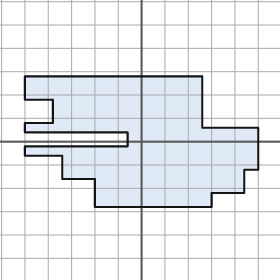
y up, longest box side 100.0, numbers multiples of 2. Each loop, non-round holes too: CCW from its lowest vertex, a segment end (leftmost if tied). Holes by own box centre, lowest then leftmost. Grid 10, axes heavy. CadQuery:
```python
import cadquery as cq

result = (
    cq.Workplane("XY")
    .moveTo(-20.0, -28.0)
    .lineTo(30.0, -28.0)
    .lineTo(30.0, -22.0)
    .lineTo(44.0, -22.0)
    .lineTo(44.0, -12.0)
    .lineTo(50.0, -12.0)
    .lineTo(50.0, 6.0)
    .lineTo(26.0, 6.0)
    .lineTo(26.0, 28.0)
    .lineTo(-50.0, 28.0)
    .lineTo(-50.0, 18.0)
    .lineTo(-38.0, 18.0)
    .lineTo(-38.0, 8.0)
    .lineTo(-50.0, 8.0)
    .lineTo(-50.0, 4.0)
    .lineTo(-6.0, 4.0)
    .lineTo(-6.0, -2.0)
    .lineTo(-50.0, -2.0)
    .lineTo(-50.0, -6.0)
    .lineTo(-34.0, -6.0)
    .lineTo(-34.0, -16.0)
    .lineTo(-20.0, -16.0)
    .close()
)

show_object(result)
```